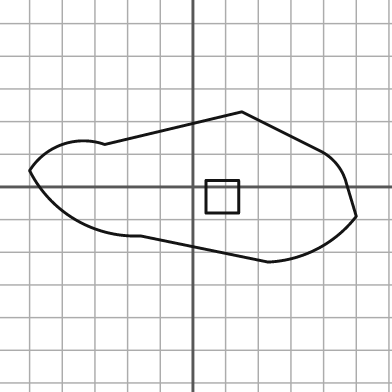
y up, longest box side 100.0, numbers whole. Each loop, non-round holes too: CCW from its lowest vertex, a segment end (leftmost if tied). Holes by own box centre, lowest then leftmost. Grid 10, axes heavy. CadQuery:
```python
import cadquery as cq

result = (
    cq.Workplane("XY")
    .moveTo(23.0, -23.0)
    .threePointArc((38.0, -19.0), (50.0, -9.0))
    .lineTo(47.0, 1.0)
    .threePointArc((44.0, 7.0), (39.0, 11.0))
    .lineTo(15.0, 23.0)
    .lineTo(-27.0, 13.0)
    .threePointArc((-40.0, 13.0), (-50.0, 5.0))
    .threePointArc((-36.0, -10.0), (-16.0, -15.0))
    .close()
    .moveTo(4.0, -8.0)
    .lineTo(14.0, -8.0)
    .lineTo(14.0, 2.0)
    .lineTo(4.0, 2.0)
    .close()
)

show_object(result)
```